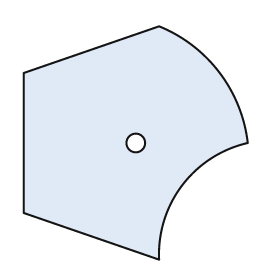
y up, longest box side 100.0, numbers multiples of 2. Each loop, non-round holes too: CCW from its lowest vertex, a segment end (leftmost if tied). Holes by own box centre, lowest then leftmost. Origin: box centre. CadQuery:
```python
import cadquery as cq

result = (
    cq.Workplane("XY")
    .moveTo(10.0, -50.0)
    .threePointArc((20.0, -18.0), (48.0, 0.0))
    .threePointArc((36.0, 30.0), (10.0, 50.0))
    .lineTo(-48.0, 30.0)
    .lineTo(-48.0, -30.0)
    .close()
    .moveTo(0.0, 0.0)
    .circle(4.0)
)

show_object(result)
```